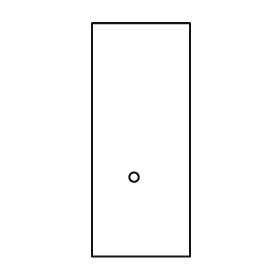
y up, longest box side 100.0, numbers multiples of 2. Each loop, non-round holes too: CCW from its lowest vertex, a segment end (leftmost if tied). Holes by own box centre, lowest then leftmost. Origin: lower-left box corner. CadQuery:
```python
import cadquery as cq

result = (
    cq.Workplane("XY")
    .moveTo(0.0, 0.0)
    .lineTo(42.0, 0.0)
    .lineTo(42.0, 100.0)
    .lineTo(0.0, 100.0)
    .close()
    .moveTo(18.0, 34.0)
    .circle(2.0)
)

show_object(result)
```